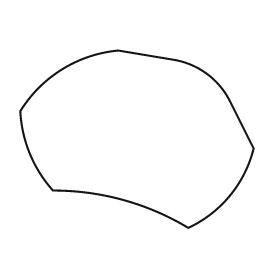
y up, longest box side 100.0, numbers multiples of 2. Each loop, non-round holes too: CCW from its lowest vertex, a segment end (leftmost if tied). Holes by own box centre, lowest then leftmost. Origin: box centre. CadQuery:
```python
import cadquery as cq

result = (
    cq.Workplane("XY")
    .moveTo(22.0, -38.0)
    .threePointArc((40.0, -24.0), (50.0, -4.0))
    .lineTo(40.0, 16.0)
    .threePointArc((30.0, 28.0), (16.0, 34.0))
    .lineTo(-8.0, 38.0)
    .threePointArc((-32.0, 30.0), (-50.0, 12.0))
    .threePointArc((-46.0, -6.0), (-36.0, -22.0))
    .threePointArc((-6.0, -26.0), (22.0, -38.0))
    .close()
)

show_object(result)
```